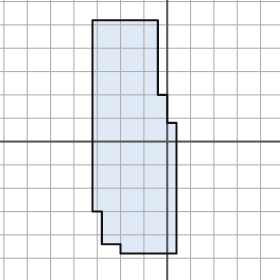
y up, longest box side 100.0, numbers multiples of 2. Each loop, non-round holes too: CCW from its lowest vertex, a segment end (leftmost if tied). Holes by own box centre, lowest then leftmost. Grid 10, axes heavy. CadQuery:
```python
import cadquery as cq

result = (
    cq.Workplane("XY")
    .moveTo(-20.0, -48.0)
    .lineTo(4.0, -48.0)
    .lineTo(4.0, 8.0)
    .lineTo(0.0, 8.0)
    .lineTo(0.0, 20.0)
    .lineTo(-4.0, 20.0)
    .lineTo(-4.0, 52.0)
    .lineTo(-32.0, 52.0)
    .lineTo(-32.0, -30.0)
    .lineTo(-28.0, -30.0)
    .lineTo(-28.0, -44.0)
    .lineTo(-20.0, -44.0)
    .close()
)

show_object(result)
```